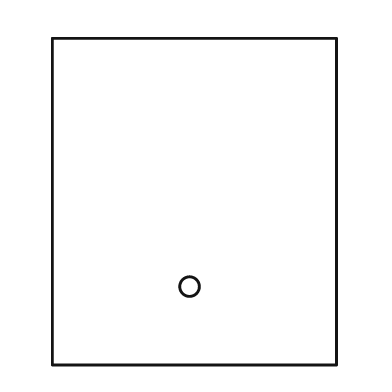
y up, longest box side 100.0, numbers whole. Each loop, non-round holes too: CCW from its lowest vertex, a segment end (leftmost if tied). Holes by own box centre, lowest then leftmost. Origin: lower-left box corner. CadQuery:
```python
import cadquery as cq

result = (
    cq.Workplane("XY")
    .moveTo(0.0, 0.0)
    .lineTo(87.0, 0.0)
    .lineTo(87.0, 100.0)
    .lineTo(0.0, 100.0)
    .close()
    .moveTo(42.0, 24.0)
    .circle(3.0)
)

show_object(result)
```